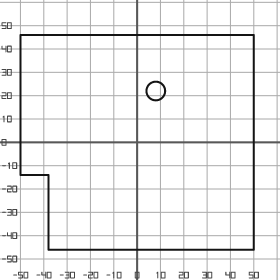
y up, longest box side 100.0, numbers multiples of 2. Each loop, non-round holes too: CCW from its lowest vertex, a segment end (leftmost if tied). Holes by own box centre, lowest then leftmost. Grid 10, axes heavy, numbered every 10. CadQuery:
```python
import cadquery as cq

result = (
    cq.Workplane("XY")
    .moveTo(-38.0, -46.0)
    .lineTo(50.0, -46.0)
    .lineTo(50.0, 46.0)
    .lineTo(-50.0, 46.0)
    .lineTo(-50.0, -14.0)
    .lineTo(-38.0, -14.0)
    .close()
    .moveTo(8.0, 22.0)
    .circle(4.0)
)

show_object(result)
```